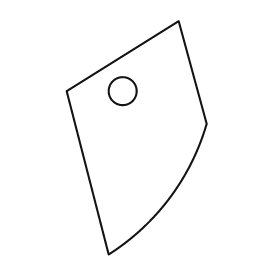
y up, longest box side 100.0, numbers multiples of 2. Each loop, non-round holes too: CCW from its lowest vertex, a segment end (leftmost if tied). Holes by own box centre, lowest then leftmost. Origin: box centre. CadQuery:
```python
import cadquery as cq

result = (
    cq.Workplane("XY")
    .moveTo(-12.0, -50.0)
    .threePointArc((14.0, -26.0), (30.0, 6.0))
    .lineTo(18.0, 50.0)
    .lineTo(-30.0, 20.0)
    .close()
    .moveTo(-6.0, 20.0)
    .circle(6.0)
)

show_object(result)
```